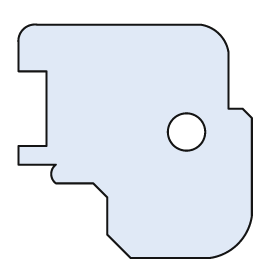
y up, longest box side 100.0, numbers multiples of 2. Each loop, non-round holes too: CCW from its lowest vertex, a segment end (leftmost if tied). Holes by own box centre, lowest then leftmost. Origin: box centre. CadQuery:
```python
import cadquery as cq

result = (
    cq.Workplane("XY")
    .moveTo(-2.0, -50.0)
    .lineTo(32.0, -50.0)
    .threePointArc((44.0, -44.0), (50.0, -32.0))
    .lineTo(50.0, 10.0)
    .lineTo(46.0, 14.0)
    .lineTo(40.0, 14.0)
    .lineTo(40.0, 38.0)
    .threePointArc((36.0, 46.0), (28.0, 50.0))
    .lineTo(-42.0, 50.0)
    .threePointArc((-48.0, 48.0), (-50.0, 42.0))
    .lineTo(-50.0, 30.0)
    .lineTo(-38.0, 30.0)
    .lineTo(-38.0, -2.0)
    .lineTo(-50.0, -2.0)
    .lineTo(-50.0, -10.0)
    .lineTo(-34.0, -10.0)
    .threePointArc((-36.0, -14.0), (-34.0, -18.0))
    .lineTo(-18.0, -18.0)
    .lineTo(-12.0, -24.0)
    .lineTo(-12.0, -40.0)
    .close()
    .moveTo(22.0, 4.0)
    .circle(8.0)
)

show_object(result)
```